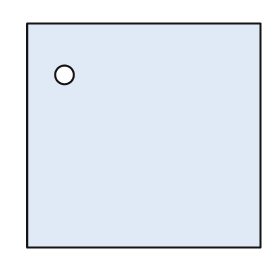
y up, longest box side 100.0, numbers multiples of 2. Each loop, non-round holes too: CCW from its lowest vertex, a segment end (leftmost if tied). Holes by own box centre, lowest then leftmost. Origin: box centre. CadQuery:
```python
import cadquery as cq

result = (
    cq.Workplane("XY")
    .moveTo(-50.0, -48.0)
    .lineTo(50.0, -48.0)
    .lineTo(50.0, 48.0)
    .lineTo(-50.0, 48.0)
    .close()
    .moveTo(-34.0, 26.0)
    .circle(4.0)
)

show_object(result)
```